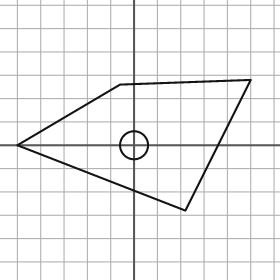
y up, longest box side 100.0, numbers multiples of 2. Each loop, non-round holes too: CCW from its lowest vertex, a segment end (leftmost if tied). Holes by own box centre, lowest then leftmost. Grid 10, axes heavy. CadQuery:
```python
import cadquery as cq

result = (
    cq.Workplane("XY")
    .moveTo(22.0, -28.0)
    .lineTo(50.0, 28.0)
    .lineTo(-6.0, 26.0)
    .lineTo(-50.0, 0.0)
    .close()
    .moveTo(0.0, 0.0)
    .circle(6.0)
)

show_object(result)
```